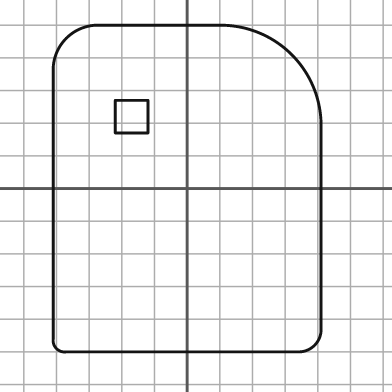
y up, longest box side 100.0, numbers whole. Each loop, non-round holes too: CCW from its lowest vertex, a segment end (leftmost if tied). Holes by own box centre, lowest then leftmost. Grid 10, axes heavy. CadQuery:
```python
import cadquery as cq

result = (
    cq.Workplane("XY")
    .moveTo(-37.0, -50.0)
    .lineTo(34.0, -50.0)
    .threePointArc((39.0, -48.0), (41.0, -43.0))
    .lineTo(41.0, 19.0)
    .threePointArc((32.0, 41.0), (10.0, 50.0))
    .lineTo(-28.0, 50.0)
    .threePointArc((-37.0, 46.0), (-41.0, 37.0))
    .lineTo(-41.0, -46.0)
    .threePointArc((-40.0, -49.0), (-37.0, -50.0))
    .close()
    .moveTo(-22.0, 17.0)
    .lineTo(-12.0, 17.0)
    .lineTo(-12.0, 27.0)
    .lineTo(-22.0, 27.0)
    .close()
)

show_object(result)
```